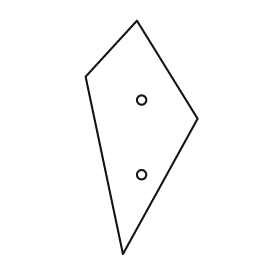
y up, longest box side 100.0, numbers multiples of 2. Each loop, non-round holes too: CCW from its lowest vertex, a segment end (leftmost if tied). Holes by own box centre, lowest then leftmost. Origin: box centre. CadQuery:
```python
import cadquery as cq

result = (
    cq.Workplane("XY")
    .moveTo(-8.0, -50.0)
    .lineTo(24.0, 8.0)
    .lineTo(-2.0, 50.0)
    .lineTo(-24.0, 26.0)
    .close()
    .moveTo(0.0, -16.0)
    .circle(2.0)
    .moveTo(0.0, 16.0)
    .circle(2.0)
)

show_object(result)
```